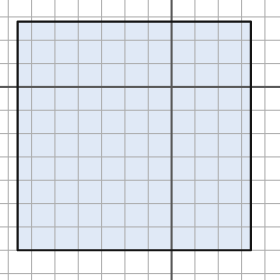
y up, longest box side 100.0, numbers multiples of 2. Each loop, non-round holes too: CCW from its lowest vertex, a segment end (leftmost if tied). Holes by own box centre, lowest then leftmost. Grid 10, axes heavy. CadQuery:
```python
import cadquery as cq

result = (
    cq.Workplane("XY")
    .moveTo(-66.0, -70.0)
    .lineTo(34.0, -70.0)
    .lineTo(34.0, 28.0)
    .lineTo(-66.0, 28.0)
    .close()
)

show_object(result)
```